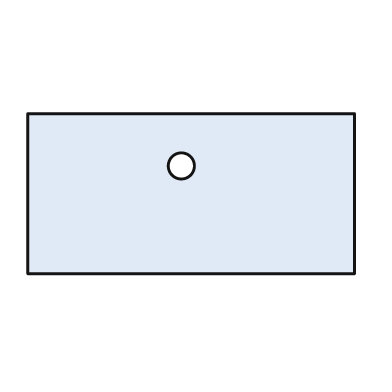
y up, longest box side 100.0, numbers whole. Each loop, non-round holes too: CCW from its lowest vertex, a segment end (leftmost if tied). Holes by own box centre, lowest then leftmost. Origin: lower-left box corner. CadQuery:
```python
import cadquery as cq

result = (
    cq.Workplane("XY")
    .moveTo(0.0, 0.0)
    .lineTo(100.0, 0.0)
    .lineTo(100.0, 49.0)
    .lineTo(0.0, 49.0)
    .close()
    .moveTo(47.0, 33.0)
    .circle(4.0)
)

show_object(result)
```